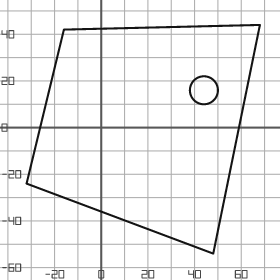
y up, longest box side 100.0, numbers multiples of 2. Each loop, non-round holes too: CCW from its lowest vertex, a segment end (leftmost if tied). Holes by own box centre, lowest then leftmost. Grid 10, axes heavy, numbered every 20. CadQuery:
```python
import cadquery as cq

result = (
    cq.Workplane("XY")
    .moveTo(48.0, -54.0)
    .lineTo(68.0, 44.0)
    .lineTo(-16.0, 42.0)
    .lineTo(-32.0, -24.0)
    .close()
    .moveTo(44.0, 16.0)
    .circle(6.0)
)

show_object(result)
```